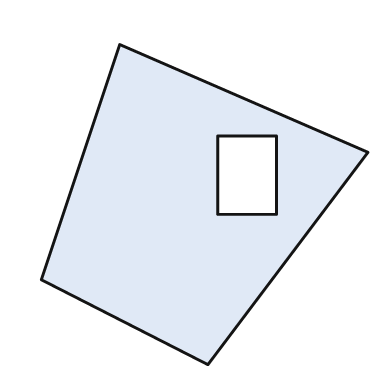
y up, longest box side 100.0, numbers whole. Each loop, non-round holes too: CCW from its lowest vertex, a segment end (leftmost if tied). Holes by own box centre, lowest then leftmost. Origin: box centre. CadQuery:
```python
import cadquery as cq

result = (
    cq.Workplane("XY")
    .moveTo(1.0, -49.0)
    .lineTo(50.0, 16.0)
    .lineTo(-26.0, 49.0)
    .lineTo(-50.0, -23.0)
    .close()
    .moveTo(4.0, -3.0)
    .lineTo(22.0, -3.0)
    .lineTo(22.0, 21.0)
    .lineTo(4.0, 21.0)
    .close()
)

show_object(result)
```